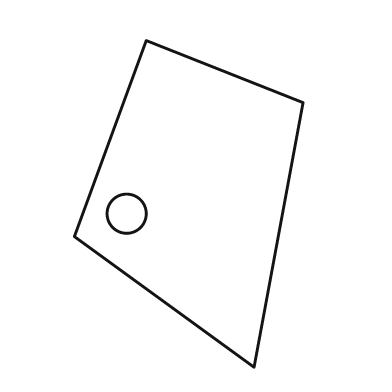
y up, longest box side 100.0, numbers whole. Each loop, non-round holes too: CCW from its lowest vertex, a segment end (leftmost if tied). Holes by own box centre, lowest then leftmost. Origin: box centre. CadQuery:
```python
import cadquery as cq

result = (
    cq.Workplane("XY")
    .moveTo(20.0, -50.0)
    .lineTo(35.0, 31.0)
    .lineTo(-13.0, 50.0)
    .lineTo(-35.0, -10.0)
    .close()
    .moveTo(-19.0, -3.0)
    .circle(6.0)
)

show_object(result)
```